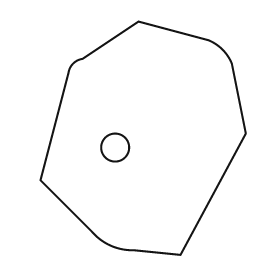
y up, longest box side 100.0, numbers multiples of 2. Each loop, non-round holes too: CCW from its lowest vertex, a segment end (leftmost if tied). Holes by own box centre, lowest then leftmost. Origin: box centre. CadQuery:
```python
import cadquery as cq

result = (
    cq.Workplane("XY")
    .moveTo(16.0, -50.0)
    .lineTo(44.0, 2.0)
    .lineTo(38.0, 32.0)
    .threePointArc((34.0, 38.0), (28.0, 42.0))
    .lineTo(-2.0, 50.0)
    .lineTo(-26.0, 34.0)
    .threePointArc((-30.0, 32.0), (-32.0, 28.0))
    .lineTo(-44.0, -18.0)
    .lineTo(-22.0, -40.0)
    .threePointArc((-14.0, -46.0), (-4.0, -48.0))
    .close()
    .moveTo(-12.0, -4.0)
    .circle(6.0)
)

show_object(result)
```